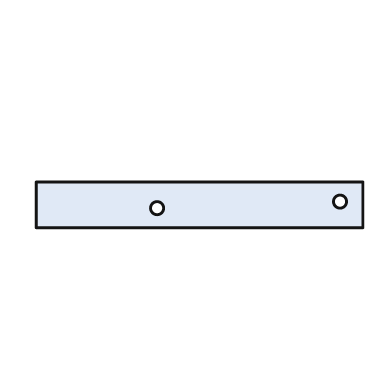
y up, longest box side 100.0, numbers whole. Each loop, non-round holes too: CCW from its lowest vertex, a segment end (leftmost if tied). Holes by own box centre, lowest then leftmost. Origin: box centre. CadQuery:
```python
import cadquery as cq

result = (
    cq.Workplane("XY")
    .moveTo(-50.0, -7.0)
    .lineTo(50.0, -7.0)
    .lineTo(50.0, 7.0)
    .lineTo(-50.0, 7.0)
    .close()
    .moveTo(-13.0, -1.0)
    .circle(2.0)
    .moveTo(43.0, 1.0)
    .circle(2.0)
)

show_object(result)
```